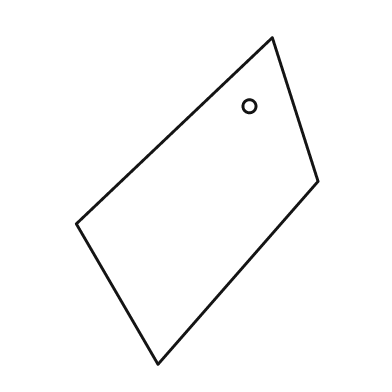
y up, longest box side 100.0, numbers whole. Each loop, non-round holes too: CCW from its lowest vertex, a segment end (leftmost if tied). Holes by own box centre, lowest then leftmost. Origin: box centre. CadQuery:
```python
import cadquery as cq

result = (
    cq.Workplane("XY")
    .moveTo(-12.0, -50.0)
    .lineTo(37.0, 6.0)
    .lineTo(23.0, 50.0)
    .lineTo(-37.0, -7.0)
    .close()
    .moveTo(16.0, 29.0)
    .circle(2.0)
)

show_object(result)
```